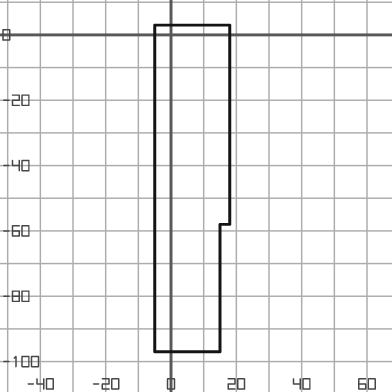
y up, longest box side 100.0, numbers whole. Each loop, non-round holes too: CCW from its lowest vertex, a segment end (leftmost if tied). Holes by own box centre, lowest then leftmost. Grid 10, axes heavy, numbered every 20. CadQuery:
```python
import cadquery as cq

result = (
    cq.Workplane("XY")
    .moveTo(-5.0, -97.0)
    .lineTo(15.0, -97.0)
    .lineTo(15.0, -58.0)
    .lineTo(18.0, -58.0)
    .lineTo(18.0, 3.0)
    .lineTo(-5.0, 3.0)
    .close()
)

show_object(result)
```